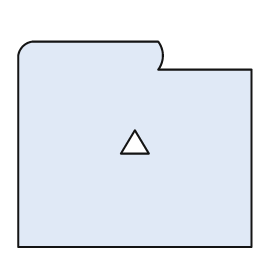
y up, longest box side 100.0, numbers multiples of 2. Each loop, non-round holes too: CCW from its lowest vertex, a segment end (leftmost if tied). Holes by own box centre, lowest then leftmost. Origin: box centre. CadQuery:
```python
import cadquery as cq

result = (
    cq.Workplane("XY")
    .moveTo(-50.0, -44.0)
    .lineTo(50.0, -44.0)
    .lineTo(50.0, 32.0)
    .lineTo(10.0, 32.0)
    .threePointArc((12.0, 38.0), (10.0, 44.0))
    .lineTo(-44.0, 44.0)
    .threePointArc((-48.0, 42.0), (-50.0, 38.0))
    .close()
    .moveTo(-6.0, -4.0)
    .lineTo(6.0, -4.0)
    .lineTo(0.0, 6.0)
    .close()
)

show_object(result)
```